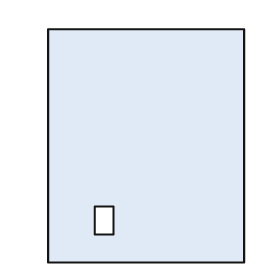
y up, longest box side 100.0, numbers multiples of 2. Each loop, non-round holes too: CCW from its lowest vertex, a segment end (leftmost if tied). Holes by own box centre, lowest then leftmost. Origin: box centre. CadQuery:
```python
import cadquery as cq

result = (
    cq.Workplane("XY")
    .moveTo(-42.0, -50.0)
    .lineTo(42.0, -50.0)
    .lineTo(42.0, 50.0)
    .lineTo(-42.0, 50.0)
    .close()
    .moveTo(-22.0, -38.0)
    .lineTo(-14.0, -38.0)
    .lineTo(-14.0, -26.0)
    .lineTo(-22.0, -26.0)
    .close()
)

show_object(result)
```